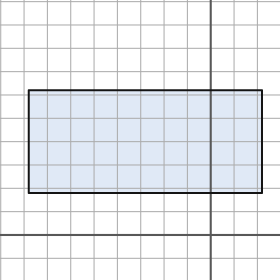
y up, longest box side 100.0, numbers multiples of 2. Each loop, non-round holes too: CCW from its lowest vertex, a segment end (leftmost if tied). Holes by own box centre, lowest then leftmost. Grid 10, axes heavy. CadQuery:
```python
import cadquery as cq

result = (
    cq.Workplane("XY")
    .moveTo(-78.0, 18.0)
    .lineTo(22.0, 18.0)
    .lineTo(22.0, 62.0)
    .lineTo(-78.0, 62.0)
    .close()
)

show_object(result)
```